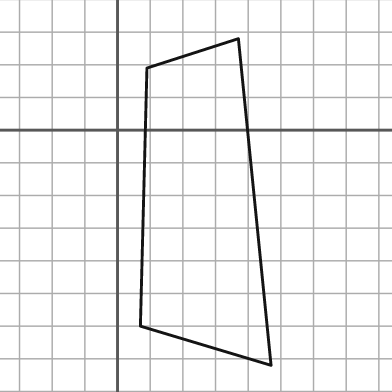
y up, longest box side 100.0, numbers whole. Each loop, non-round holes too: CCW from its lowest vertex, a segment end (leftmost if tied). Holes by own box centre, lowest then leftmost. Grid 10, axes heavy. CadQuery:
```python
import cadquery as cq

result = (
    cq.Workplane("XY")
    .moveTo(47.0, -72.0)
    .lineTo(37.0, 28.0)
    .lineTo(9.0, 19.0)
    .lineTo(7.0, -60.0)
    .close()
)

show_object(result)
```